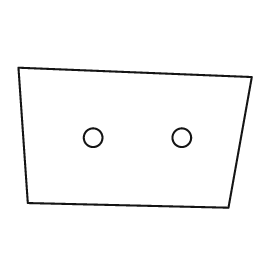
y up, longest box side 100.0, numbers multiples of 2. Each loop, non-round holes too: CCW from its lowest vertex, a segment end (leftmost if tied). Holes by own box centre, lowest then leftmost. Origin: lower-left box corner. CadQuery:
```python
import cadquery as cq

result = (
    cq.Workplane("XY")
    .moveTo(90.0, 0.0)
    .lineTo(100.0, 56.0)
    .lineTo(0.0, 60.0)
    .lineTo(4.0, 2.0)
    .close()
    .moveTo(32.0, 30.0)
    .circle(4.0)
    .moveTo(70.0, 30.0)
    .circle(4.0)
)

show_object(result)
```